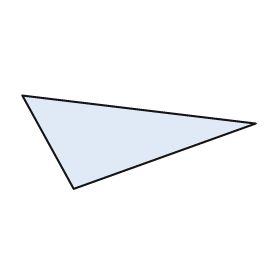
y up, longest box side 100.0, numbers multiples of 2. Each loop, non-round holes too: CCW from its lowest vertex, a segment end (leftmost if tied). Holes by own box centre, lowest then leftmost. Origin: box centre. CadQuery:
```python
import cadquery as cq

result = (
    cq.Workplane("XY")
    .moveTo(-28.0, -20.0)
    .lineTo(50.0, 8.0)
    .lineTo(-50.0, 20.0)
    .close()
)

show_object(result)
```